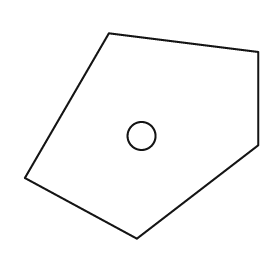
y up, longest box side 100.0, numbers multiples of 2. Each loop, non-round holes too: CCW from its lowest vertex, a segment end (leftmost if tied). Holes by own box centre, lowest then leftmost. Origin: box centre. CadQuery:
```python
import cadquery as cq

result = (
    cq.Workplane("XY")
    .moveTo(-2.0, -44.0)
    .lineTo(50.0, -4.0)
    .lineTo(50.0, 36.0)
    .lineTo(-14.0, 44.0)
    .lineTo(-50.0, -18.0)
    .close()
    .moveTo(0.0, 0.0)
    .circle(6.0)
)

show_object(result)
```